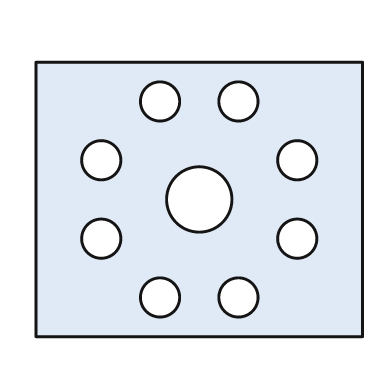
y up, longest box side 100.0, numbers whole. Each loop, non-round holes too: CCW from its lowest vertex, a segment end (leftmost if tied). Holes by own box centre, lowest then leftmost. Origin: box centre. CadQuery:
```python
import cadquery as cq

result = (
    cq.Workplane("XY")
    .moveTo(-50.0, -42.0)
    .lineTo(50.0, -42.0)
    .lineTo(50.0, 42.0)
    .lineTo(-50.0, 42.0)
    .close()
    .moveTo(-12.0, -30.0)
    .circle(6.0)
    .moveTo(12.0, -30.0)
    .circle(6.0)
    .moveTo(-30.0, -12.0)
    .circle(6.0)
    .moveTo(30.0, -12.0)
    .circle(6.0)
    .moveTo(0.0, 0.0)
    .circle(10.0)
    .moveTo(-30.0, 12.0)
    .circle(6.0)
    .moveTo(30.0, 12.0)
    .circle(6.0)
    .moveTo(-12.0, 30.0)
    .circle(6.0)
    .moveTo(12.0, 30.0)
    .circle(6.0)
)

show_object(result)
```